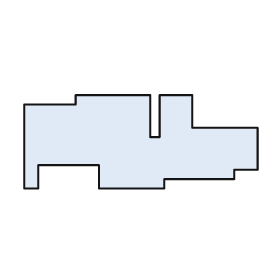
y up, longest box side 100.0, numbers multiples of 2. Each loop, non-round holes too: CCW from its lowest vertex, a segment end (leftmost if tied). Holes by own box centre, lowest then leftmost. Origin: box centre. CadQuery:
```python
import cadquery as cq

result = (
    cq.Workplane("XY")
    .moveTo(-50.0, -20.0)
    .lineTo(-44.0, -20.0)
    .lineTo(-44.0, -10.0)
    .lineTo(-18.0, -10.0)
    .lineTo(-18.0, -20.0)
    .lineTo(10.0, -20.0)
    .lineTo(10.0, -16.0)
    .lineTo(40.0, -16.0)
    .lineTo(40.0, -12.0)
    .lineTo(50.0, -12.0)
    .lineTo(50.0, 6.0)
    .lineTo(22.0, 6.0)
    .lineTo(22.0, 20.0)
    .lineTo(8.0, 20.0)
    .lineTo(8.0, 2.0)
    .lineTo(4.0, 2.0)
    .lineTo(4.0, 20.0)
    .lineTo(-28.0, 20.0)
    .lineTo(-28.0, 16.0)
    .lineTo(-50.0, 16.0)
    .close()
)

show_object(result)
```